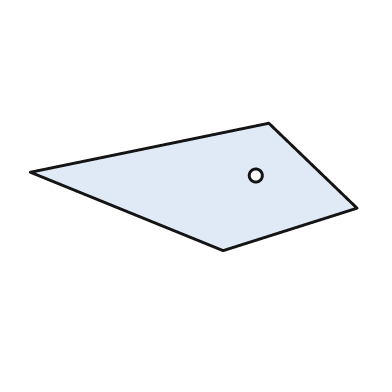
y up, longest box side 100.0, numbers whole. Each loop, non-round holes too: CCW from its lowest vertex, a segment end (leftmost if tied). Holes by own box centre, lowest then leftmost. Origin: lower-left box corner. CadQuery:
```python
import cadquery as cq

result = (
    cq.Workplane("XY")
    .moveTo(59.0, 0.0)
    .lineTo(100.0, 13.0)
    .lineTo(73.0, 39.0)
    .lineTo(0.0, 24.0)
    .close()
    .moveTo(69.0, 23.0)
    .circle(2.0)
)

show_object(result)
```